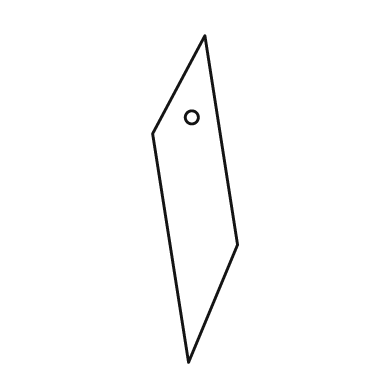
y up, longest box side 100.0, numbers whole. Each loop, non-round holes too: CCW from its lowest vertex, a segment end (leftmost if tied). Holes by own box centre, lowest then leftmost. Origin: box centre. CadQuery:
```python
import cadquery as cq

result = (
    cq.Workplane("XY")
    .moveTo(-2.0, -50.0)
    .lineTo(13.0, -14.0)
    .lineTo(3.0, 50.0)
    .lineTo(-13.0, 20.0)
    .close()
    .moveTo(-1.0, 25.0)
    .circle(2.0)
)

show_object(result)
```